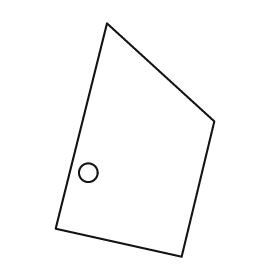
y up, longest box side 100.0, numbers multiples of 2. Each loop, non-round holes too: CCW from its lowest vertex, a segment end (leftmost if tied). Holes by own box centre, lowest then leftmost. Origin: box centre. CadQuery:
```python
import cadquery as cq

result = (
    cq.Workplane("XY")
    .moveTo(20.0, -50.0)
    .lineTo(34.0, 8.0)
    .lineTo(-12.0, 50.0)
    .lineTo(-34.0, -38.0)
    .close()
    .moveTo(-20.0, -14.0)
    .circle(4.0)
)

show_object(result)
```